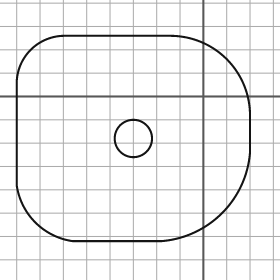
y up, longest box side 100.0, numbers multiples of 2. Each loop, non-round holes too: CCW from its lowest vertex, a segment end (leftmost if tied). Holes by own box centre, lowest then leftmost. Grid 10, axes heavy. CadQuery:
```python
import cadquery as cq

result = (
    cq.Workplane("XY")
    .moveTo(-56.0, -62.0)
    .lineTo(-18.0, -62.0)
    .threePointArc((8.0, -50.0), (20.0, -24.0))
    .lineTo(20.0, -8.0)
    .threePointArc((10.0, 16.0), (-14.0, 26.0))
    .lineTo(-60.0, 26.0)
    .threePointArc((-74.0, 20.0), (-80.0, 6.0))
    .lineTo(-80.0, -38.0)
    .threePointArc((-72.0, -54.0), (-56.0, -62.0))
    .close()
    .moveTo(-30.0, -18.0)
    .circle(8.0)
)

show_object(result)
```